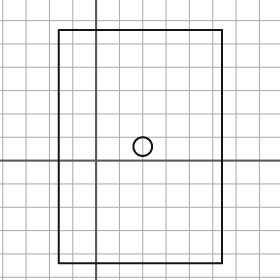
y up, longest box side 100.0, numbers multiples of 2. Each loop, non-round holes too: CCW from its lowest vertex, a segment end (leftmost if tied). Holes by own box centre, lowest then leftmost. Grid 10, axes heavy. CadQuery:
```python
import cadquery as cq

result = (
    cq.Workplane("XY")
    .moveTo(-16.0, -44.0)
    .lineTo(54.0, -44.0)
    .lineTo(54.0, 56.0)
    .lineTo(-16.0, 56.0)
    .close()
    .moveTo(20.0, 6.0)
    .circle(4.0)
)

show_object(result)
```